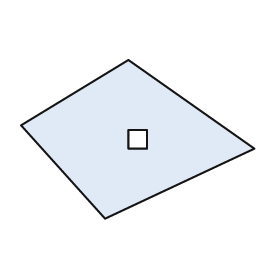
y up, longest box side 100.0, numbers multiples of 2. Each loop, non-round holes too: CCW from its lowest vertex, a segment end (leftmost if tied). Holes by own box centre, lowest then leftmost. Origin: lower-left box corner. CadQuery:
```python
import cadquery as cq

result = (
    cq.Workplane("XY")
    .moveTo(36.0, 0.0)
    .lineTo(100.0, 30.0)
    .lineTo(46.0, 68.0)
    .lineTo(0.0, 40.0)
    .close()
    .moveTo(46.0, 30.0)
    .lineTo(54.0, 30.0)
    .lineTo(54.0, 38.0)
    .lineTo(46.0, 38.0)
    .close()
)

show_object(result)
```